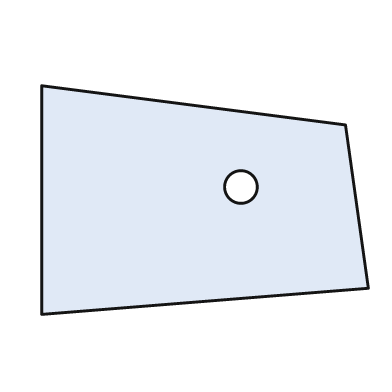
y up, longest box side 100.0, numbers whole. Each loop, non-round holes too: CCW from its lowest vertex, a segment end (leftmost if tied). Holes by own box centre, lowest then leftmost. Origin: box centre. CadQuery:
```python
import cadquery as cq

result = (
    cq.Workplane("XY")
    .moveTo(-50.0, -35.0)
    .lineTo(50.0, -27.0)
    .lineTo(43.0, 23.0)
    .lineTo(-50.0, 35.0)
    .close()
    .moveTo(11.0, 4.0)
    .circle(5.0)
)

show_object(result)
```